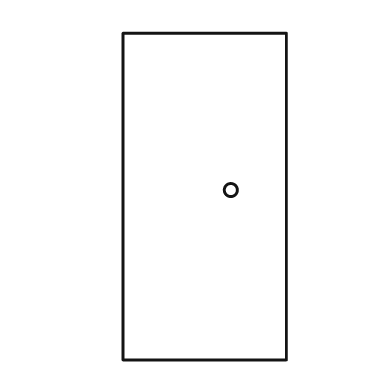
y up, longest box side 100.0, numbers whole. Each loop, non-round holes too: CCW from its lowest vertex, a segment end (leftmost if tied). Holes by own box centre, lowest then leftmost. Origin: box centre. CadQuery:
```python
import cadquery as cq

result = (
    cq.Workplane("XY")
    .moveTo(-25.0, -50.0)
    .lineTo(25.0, -50.0)
    .lineTo(25.0, 50.0)
    .lineTo(-25.0, 50.0)
    .close()
    .moveTo(8.0, 2.0)
    .circle(2.0)
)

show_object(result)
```